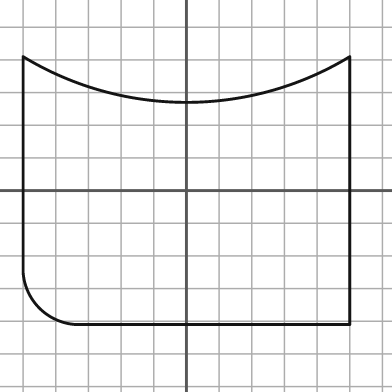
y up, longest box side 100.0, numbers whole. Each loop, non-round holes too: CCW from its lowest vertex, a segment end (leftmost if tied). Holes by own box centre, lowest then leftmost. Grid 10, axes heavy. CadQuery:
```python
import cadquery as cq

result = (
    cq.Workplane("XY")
    .moveTo(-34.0, -41.0)
    .lineTo(50.0, -41.0)
    .lineTo(50.0, 41.0)
    .threePointArc((0.0, 27.0), (-50.0, 41.0))
    .lineTo(-50.0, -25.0)
    .threePointArc((-45.0, -36.0), (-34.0, -41.0))
    .close()
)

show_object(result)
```